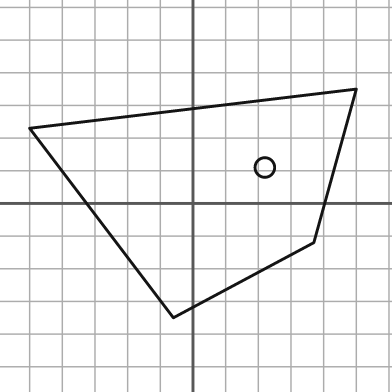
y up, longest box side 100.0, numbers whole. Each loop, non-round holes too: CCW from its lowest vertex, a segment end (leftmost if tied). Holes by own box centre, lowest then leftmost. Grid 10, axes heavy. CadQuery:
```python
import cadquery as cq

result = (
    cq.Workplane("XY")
    .moveTo(-6.0, -35.0)
    .lineTo(37.0, -12.0)
    .lineTo(50.0, 35.0)
    .lineTo(-50.0, 23.0)
    .close()
    .moveTo(22.0, 11.0)
    .circle(3.0)
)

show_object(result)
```